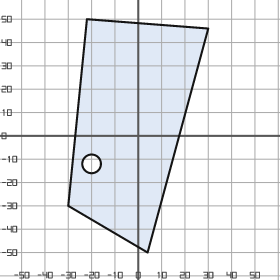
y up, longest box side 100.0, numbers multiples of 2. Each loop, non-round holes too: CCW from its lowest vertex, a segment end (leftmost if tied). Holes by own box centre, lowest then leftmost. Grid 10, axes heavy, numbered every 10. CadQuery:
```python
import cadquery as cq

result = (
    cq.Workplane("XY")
    .moveTo(4.0, -50.0)
    .lineTo(30.0, 46.0)
    .lineTo(-22.0, 50.0)
    .lineTo(-30.0, -30.0)
    .close()
    .moveTo(-20.0, -12.0)
    .circle(4.0)
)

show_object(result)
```